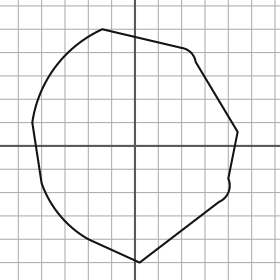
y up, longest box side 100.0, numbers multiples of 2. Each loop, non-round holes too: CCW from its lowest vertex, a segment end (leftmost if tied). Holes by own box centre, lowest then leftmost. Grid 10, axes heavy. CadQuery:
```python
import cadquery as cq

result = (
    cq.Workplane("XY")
    .moveTo(2.0, -50.0)
    .lineTo(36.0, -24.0)
    .threePointArc((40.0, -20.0), (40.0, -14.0))
    .lineTo(44.0, 6.0)
    .lineTo(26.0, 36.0)
    .threePointArc((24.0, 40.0), (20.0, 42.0))
    .lineTo(-14.0, 50.0)
    .threePointArc((-34.0, 34.0), (-44.0, 10.0))
    .lineTo(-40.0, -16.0)
    .threePointArc((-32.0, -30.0), (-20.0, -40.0))
    .close()
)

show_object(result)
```